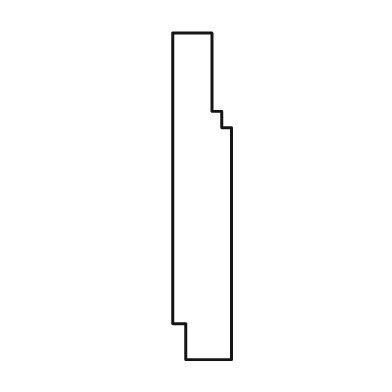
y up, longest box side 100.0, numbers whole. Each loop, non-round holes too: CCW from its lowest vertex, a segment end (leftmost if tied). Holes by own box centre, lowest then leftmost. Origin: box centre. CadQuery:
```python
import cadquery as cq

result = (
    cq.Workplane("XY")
    .moveTo(-5.0, -50.0)
    .lineTo(9.0, -50.0)
    .lineTo(9.0, 21.0)
    .lineTo(6.0, 21.0)
    .lineTo(6.0, 26.0)
    .lineTo(3.0, 26.0)
    .lineTo(3.0, 50.0)
    .lineTo(-9.0, 50.0)
    .lineTo(-9.0, -39.0)
    .lineTo(-5.0, -39.0)
    .close()
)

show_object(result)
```